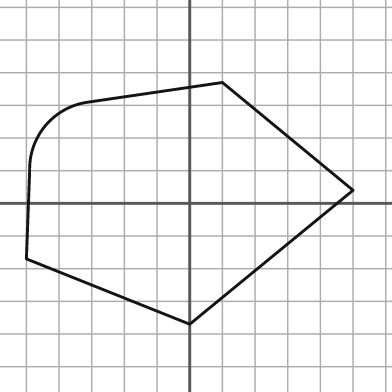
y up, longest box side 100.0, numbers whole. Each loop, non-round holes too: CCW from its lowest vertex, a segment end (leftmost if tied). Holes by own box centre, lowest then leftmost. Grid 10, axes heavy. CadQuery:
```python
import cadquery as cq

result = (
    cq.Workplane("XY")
    .moveTo(0.0, -37.0)
    .lineTo(50.0, 4.0)
    .lineTo(10.0, 37.0)
    .lineTo(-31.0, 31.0)
    .threePointArc((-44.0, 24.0), (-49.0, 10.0))
    .lineTo(-50.0, -17.0)
    .close()
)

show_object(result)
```